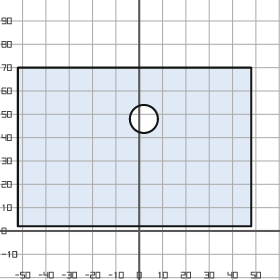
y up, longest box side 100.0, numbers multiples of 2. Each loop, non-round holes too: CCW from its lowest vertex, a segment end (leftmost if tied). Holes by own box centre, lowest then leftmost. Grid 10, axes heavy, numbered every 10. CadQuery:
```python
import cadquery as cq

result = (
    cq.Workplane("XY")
    .moveTo(-52.0, 2.0)
    .lineTo(48.0, 2.0)
    .lineTo(48.0, 70.0)
    .lineTo(-52.0, 70.0)
    .close()
    .moveTo(2.0, 48.0)
    .circle(6.0)
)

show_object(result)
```